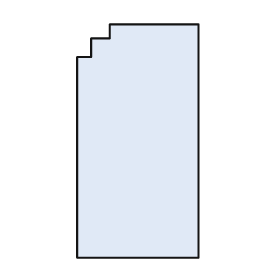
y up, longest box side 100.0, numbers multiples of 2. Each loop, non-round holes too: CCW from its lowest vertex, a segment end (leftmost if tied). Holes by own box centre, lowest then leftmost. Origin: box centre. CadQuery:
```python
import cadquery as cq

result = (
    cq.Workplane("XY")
    .moveTo(-26.0, -50.0)
    .lineTo(26.0, -50.0)
    .lineTo(26.0, 50.0)
    .lineTo(-12.0, 50.0)
    .lineTo(-12.0, 44.0)
    .lineTo(-20.0, 44.0)
    .lineTo(-20.0, 36.0)
    .lineTo(-26.0, 36.0)
    .close()
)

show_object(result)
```